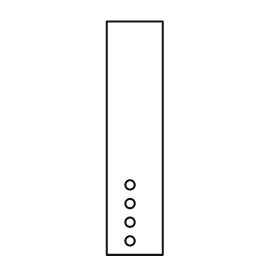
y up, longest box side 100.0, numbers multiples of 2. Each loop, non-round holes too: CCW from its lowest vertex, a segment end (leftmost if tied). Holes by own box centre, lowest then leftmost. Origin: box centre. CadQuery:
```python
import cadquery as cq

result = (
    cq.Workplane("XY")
    .moveTo(-12.0, -50.0)
    .lineTo(12.0, -50.0)
    .lineTo(12.0, 50.0)
    .lineTo(-12.0, 50.0)
    .close()
    .moveTo(-2.0, -44.0)
    .circle(2.0)
    .moveTo(-2.0, -36.0)
    .circle(2.0)
    .moveTo(-2.0, -28.0)
    .circle(2.0)
    .moveTo(-2.0, -20.0)
    .circle(2.0)
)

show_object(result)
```